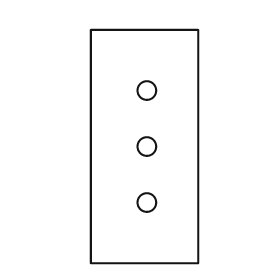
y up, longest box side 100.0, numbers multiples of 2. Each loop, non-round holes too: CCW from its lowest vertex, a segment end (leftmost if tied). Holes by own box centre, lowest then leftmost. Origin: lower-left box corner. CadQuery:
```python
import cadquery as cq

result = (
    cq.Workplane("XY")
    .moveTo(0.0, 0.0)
    .lineTo(46.0, 0.0)
    .lineTo(46.0, 100.0)
    .lineTo(0.0, 100.0)
    .close()
    .moveTo(24.0, 26.0)
    .circle(4.0)
    .moveTo(24.0, 50.0)
    .circle(4.0)
    .moveTo(24.0, 74.0)
    .circle(4.0)
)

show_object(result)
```